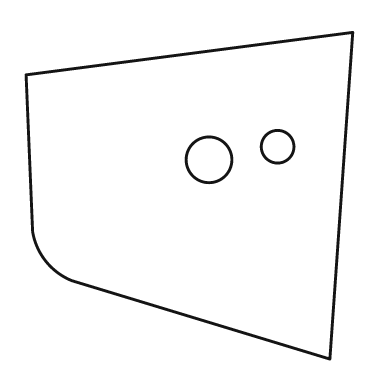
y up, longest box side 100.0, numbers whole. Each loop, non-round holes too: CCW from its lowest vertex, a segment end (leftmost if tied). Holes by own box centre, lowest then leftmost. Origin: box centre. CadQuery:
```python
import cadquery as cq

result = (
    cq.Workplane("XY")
    .moveTo(43.0, -50.0)
    .lineTo(50.0, 50.0)
    .lineTo(-50.0, 37.0)
    .lineTo(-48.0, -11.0)
    .threePointArc((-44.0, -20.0), (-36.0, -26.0))
    .close()
    .moveTo(6.0, 11.0)
    .circle(7.0)
    .moveTo(27.0, 15.0)
    .circle(5.0)
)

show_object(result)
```